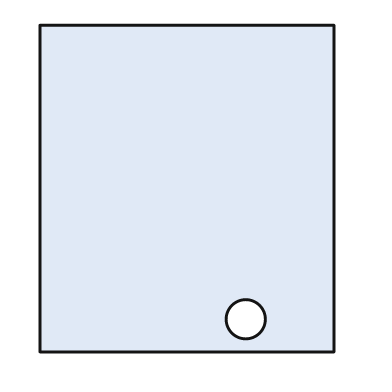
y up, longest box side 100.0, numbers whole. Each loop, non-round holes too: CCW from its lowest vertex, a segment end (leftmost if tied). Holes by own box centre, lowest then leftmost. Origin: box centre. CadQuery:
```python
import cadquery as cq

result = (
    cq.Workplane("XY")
    .moveTo(-45.0, -50.0)
    .lineTo(45.0, -50.0)
    .lineTo(45.0, 50.0)
    .lineTo(-45.0, 50.0)
    .close()
    .moveTo(18.0, -40.0)
    .circle(6.0)
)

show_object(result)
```